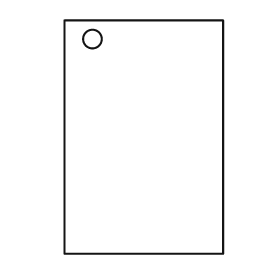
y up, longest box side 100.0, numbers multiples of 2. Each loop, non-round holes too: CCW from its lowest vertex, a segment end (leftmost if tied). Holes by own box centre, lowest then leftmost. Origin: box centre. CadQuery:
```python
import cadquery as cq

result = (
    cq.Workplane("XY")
    .moveTo(-34.0, -50.0)
    .lineTo(34.0, -50.0)
    .lineTo(34.0, 50.0)
    .lineTo(-34.0, 50.0)
    .close()
    .moveTo(-22.0, 42.0)
    .circle(4.0)
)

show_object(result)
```